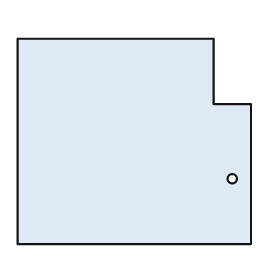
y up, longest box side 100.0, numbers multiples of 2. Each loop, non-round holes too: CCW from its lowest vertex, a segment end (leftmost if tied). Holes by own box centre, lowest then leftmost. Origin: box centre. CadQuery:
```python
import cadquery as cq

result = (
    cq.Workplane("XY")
    .moveTo(-50.0, -44.0)
    .lineTo(50.0, -44.0)
    .lineTo(50.0, 16.0)
    .lineTo(34.0, 16.0)
    .lineTo(34.0, 44.0)
    .lineTo(-50.0, 44.0)
    .close()
    .moveTo(42.0, -16.0)
    .circle(2.0)
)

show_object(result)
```